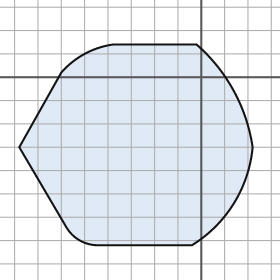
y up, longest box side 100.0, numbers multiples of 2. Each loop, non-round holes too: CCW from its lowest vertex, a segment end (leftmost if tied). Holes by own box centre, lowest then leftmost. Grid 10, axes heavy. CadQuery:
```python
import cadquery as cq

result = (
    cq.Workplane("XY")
    .moveTo(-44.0, -72.0)
    .lineTo(-4.0, -72.0)
    .threePointArc((14.0, -54.0), (22.0, -30.0))
    .threePointArc((14.0, -6.0), (-2.0, 14.0))
    .lineTo(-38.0, 14.0)
    .threePointArc((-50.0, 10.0), (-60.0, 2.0))
    .lineTo(-78.0, -30.0)
    .lineTo(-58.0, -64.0)
    .threePointArc((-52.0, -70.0), (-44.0, -72.0))
    .close()
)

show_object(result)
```